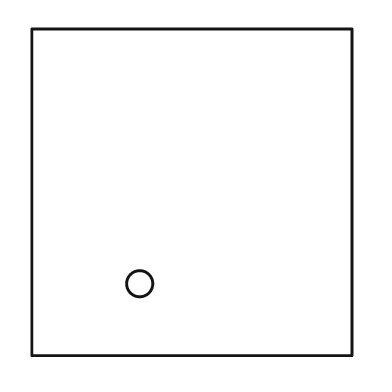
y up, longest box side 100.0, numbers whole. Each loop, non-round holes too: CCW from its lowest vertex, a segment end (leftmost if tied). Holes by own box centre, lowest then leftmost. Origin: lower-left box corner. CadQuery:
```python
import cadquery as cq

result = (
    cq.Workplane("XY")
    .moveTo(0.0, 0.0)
    .lineTo(98.0, 0.0)
    .lineTo(98.0, 100.0)
    .lineTo(0.0, 100.0)
    .close()
    .moveTo(33.0, 22.0)
    .circle(4.0)
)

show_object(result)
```